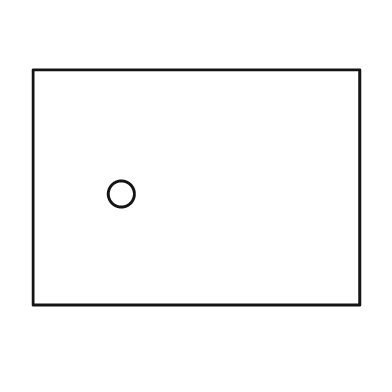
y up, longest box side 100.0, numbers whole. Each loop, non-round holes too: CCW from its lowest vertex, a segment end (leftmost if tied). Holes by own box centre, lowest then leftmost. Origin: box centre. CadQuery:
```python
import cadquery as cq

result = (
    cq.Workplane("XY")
    .moveTo(-50.0, -36.0)
    .lineTo(50.0, -36.0)
    .lineTo(50.0, 36.0)
    .lineTo(-50.0, 36.0)
    .close()
    .moveTo(-23.0, -2.0)
    .circle(4.0)
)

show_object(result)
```